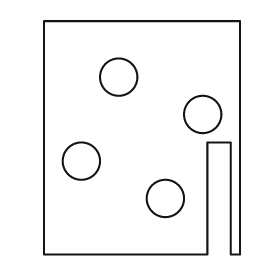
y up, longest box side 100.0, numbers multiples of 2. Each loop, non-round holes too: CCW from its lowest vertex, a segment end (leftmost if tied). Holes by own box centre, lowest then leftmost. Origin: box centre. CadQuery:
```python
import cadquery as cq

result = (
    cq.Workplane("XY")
    .moveTo(-42.0, -50.0)
    .lineTo(28.0, -50.0)
    .lineTo(28.0, -2.0)
    .lineTo(38.0, -2.0)
    .lineTo(38.0, -50.0)
    .lineTo(42.0, -50.0)
    .lineTo(42.0, 50.0)
    .lineTo(-42.0, 50.0)
    .close()
    .moveTo(10.0, -26.0)
    .circle(8.0)
    .moveTo(-26.0, -10.0)
    .circle(8.0)
    .moveTo(26.0, 10.0)
    .circle(8.0)
    .moveTo(-10.0, 26.0)
    .circle(8.0)
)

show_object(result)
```